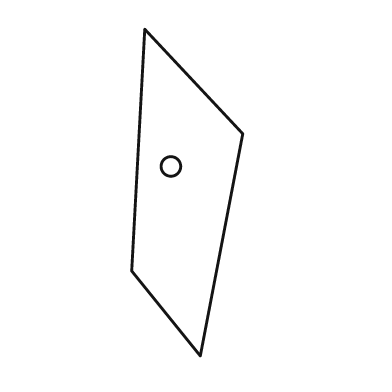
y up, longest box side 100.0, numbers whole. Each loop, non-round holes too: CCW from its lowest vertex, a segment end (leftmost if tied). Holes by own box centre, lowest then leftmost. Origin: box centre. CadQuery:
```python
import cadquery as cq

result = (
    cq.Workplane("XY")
    .moveTo(4.0, -50.0)
    .lineTo(17.0, 18.0)
    .lineTo(-13.0, 50.0)
    .lineTo(-17.0, -24.0)
    .close()
    .moveTo(-5.0, 8.0)
    .circle(3.0)
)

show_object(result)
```